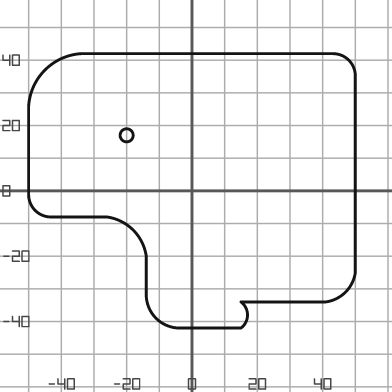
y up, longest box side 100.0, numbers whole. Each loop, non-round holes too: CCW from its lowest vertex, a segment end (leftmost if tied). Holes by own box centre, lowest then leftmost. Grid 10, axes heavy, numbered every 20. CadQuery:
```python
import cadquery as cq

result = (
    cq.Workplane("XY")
    .moveTo(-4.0, -42.0)
    .lineTo(15.0, -42.0)
    .threePointArc((17.0, -38.0), (15.0, -34.0))
    .lineTo(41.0, -34.0)
    .threePointArc((47.0, -31.0), (50.0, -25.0))
    .lineTo(50.0, 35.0)
    .threePointArc((48.0, 40.0), (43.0, 42.0))
    .lineTo(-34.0, 42.0)
    .threePointArc((-45.0, 37.0), (-50.0, 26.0))
    .lineTo(-50.0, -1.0)
    .threePointArc((-48.0, -6.0), (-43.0, -8.0))
    .lineTo(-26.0, -8.0)
    .threePointArc((-18.0, -12.0), (-14.0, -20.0))
    .lineTo(-14.0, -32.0)
    .threePointArc((-11.0, -39.0), (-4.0, -42.0))
    .close()
    .moveTo(-20.0, 17.0)
    .circle(2.0)
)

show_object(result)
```